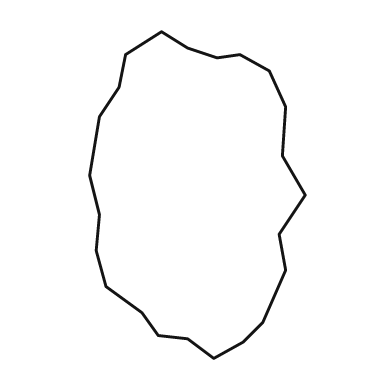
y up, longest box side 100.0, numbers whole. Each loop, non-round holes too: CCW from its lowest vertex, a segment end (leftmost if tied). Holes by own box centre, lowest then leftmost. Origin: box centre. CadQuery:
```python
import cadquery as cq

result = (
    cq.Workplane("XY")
    .moveTo(5.0, -50.0)
    .lineTo(14.0, -45.0)
    .lineTo(20.0, -39.0)
    .lineTo(27.0, -23.0)
    .lineTo(25.0, -12.0)
    .lineTo(33.0, 0.0)
    .lineTo(26.0, 12.0)
    .lineTo(27.0, 27.0)
    .lineTo(22.0, 38.0)
    .lineTo(13.0, 43.0)
    .lineTo(6.0, 42.0)
    .lineTo(-3.0, 45.0)
    .lineTo(-11.0, 50.0)
    .lineTo(-22.0, 43.0)
    .lineTo(-24.0, 33.0)
    .lineTo(-30.0, 24.0)
    .lineTo(-33.0, 6.0)
    .lineTo(-30.0, -6.0)
    .lineTo(-31.0, -17.0)
    .lineTo(-28.0, -28.0)
    .lineTo(-17.0, -36.0)
    .lineTo(-12.0, -43.0)
    .lineTo(-3.0, -44.0)
    .close()
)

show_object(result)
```